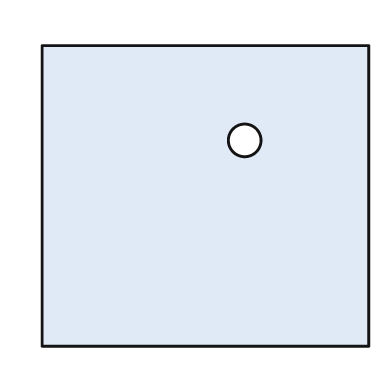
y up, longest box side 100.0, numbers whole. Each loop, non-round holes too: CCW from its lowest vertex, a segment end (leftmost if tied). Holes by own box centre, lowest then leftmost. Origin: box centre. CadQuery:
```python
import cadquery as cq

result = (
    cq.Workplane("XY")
    .moveTo(-50.0, -46.0)
    .lineTo(50.0, -46.0)
    .lineTo(50.0, 46.0)
    .lineTo(-50.0, 46.0)
    .close()
    .moveTo(12.0, 17.0)
    .circle(5.0)
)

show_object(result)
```